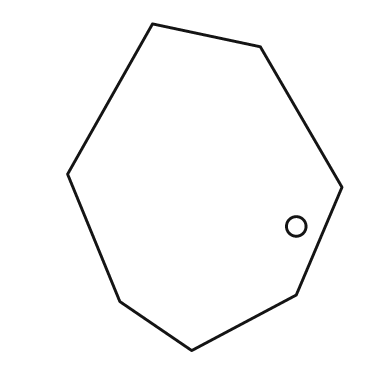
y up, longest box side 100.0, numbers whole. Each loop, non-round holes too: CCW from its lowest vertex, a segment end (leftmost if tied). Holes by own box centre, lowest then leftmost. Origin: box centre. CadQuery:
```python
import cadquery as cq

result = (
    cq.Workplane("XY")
    .moveTo(-4.0, -50.0)
    .lineTo(28.0, -33.0)
    .lineTo(42.0, 0.0)
    .lineTo(17.0, 43.0)
    .lineTo(-16.0, 50.0)
    .lineTo(-42.0, 4.0)
    .lineTo(-26.0, -35.0)
    .close()
    .moveTo(28.0, -12.0)
    .circle(3.0)
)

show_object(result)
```